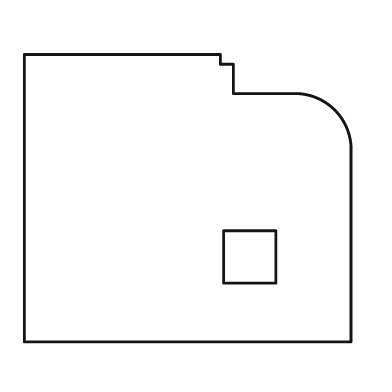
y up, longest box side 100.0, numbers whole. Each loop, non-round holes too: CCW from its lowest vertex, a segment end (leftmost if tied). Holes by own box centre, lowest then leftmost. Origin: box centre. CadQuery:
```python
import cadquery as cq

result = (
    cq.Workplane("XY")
    .moveTo(-50.0, -44.0)
    .lineTo(50.0, -44.0)
    .lineTo(50.0, 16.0)
    .threePointArc((45.0, 27.0), (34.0, 32.0))
    .lineTo(14.0, 32.0)
    .lineTo(14.0, 41.0)
    .lineTo(10.0, 41.0)
    .lineTo(10.0, 44.0)
    .lineTo(-50.0, 44.0)
    .close()
    .moveTo(11.0, -26.0)
    .lineTo(27.0, -26.0)
    .lineTo(27.0, -10.0)
    .lineTo(11.0, -10.0)
    .close()
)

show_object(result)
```